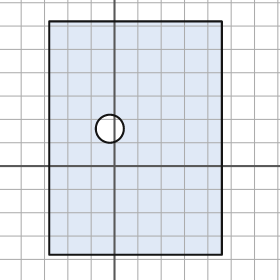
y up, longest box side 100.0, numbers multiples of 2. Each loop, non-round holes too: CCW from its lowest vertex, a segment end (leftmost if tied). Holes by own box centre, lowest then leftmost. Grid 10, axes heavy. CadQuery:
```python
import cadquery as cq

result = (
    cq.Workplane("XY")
    .moveTo(-28.0, -38.0)
    .lineTo(46.0, -38.0)
    .lineTo(46.0, 62.0)
    .lineTo(-28.0, 62.0)
    .close()
    .moveTo(-2.0, 16.0)
    .circle(6.0)
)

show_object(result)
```